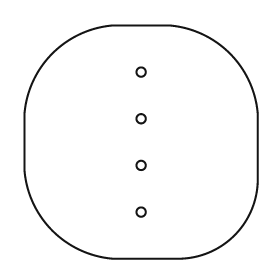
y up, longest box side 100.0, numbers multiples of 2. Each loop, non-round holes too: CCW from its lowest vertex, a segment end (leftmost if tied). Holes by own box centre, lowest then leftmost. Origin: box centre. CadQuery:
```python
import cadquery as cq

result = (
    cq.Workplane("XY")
    .moveTo(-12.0, -50.0)
    .lineTo(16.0, -50.0)
    .threePointArc((40.0, -40.0), (50.0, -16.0))
    .lineTo(50.0, 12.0)
    .threePointArc((38.0, 38.0), (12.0, 50.0))
    .lineTo(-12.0, 50.0)
    .threePointArc((-38.0, 38.0), (-50.0, 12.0))
    .lineTo(-50.0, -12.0)
    .threePointArc((-38.0, -38.0), (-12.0, -50.0))
    .close()
    .moveTo(0.0, -30.0)
    .circle(2.0)
    .moveTo(0.0, -10.0)
    .circle(2.0)
    .moveTo(0.0, 10.0)
    .circle(2.0)
    .moveTo(0.0, 30.0)
    .circle(2.0)
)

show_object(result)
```